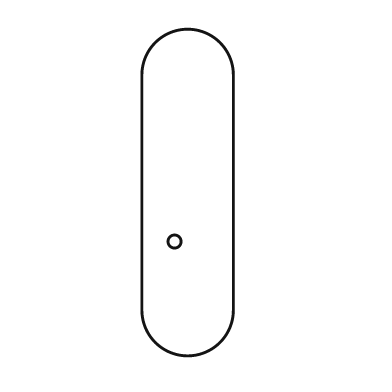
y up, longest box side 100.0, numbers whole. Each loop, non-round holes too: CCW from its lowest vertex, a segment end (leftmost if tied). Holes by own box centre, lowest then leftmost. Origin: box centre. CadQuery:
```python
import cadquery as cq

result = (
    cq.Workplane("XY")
    .moveTo(-14.0, -36.0)
    .threePointArc((0.0, -50.0), (14.0, -36.0))
    .lineTo(14.0, 36.0)
    .threePointArc((0.0, 50.0), (-14.0, 36.0))
    .close()
    .moveTo(-4.0, -15.0)
    .circle(2.0)
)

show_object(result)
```